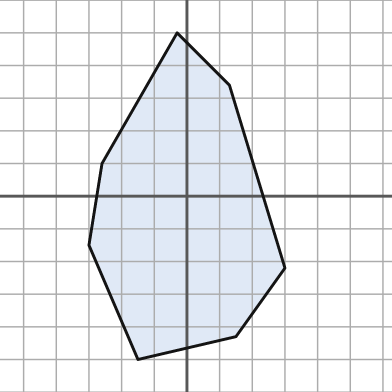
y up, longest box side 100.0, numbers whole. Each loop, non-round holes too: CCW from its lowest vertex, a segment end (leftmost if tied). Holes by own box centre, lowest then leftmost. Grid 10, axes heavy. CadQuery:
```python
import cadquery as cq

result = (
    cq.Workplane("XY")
    .moveTo(-15.0, -50.0)
    .lineTo(15.0, -43.0)
    .lineTo(30.0, -22.0)
    .lineTo(13.0, 34.0)
    .lineTo(-3.0, 50.0)
    .lineTo(-26.0, 10.0)
    .lineTo(-30.0, -15.0)
    .close()
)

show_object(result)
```